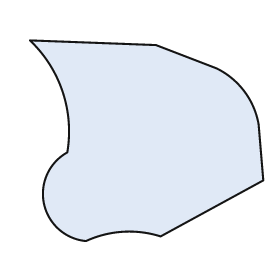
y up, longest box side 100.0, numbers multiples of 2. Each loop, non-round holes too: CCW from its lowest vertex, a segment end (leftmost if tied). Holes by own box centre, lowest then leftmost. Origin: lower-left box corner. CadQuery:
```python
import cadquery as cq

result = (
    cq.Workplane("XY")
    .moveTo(24.0, 0.0)
    .threePointArc((40.0, 4.0), (56.0, 2.0))
    .lineTo(100.0, 26.0)
    .lineTo(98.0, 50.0)
    .threePointArc((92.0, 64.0), (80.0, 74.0))
    .lineTo(54.0, 84.0)
    .lineTo(0.0, 86.0)
    .threePointArc((14.0, 64.0), (16.0, 38.0))
    .threePointArc((6.0, 16.0), (24.0, 0.0))
    .close()
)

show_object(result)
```